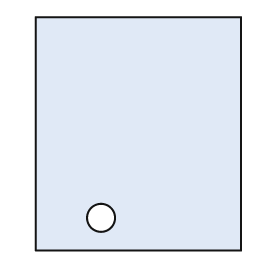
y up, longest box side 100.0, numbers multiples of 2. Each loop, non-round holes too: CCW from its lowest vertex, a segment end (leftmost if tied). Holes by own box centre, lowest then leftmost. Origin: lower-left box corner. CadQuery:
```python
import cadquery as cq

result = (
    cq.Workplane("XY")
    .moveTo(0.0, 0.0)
    .lineTo(88.0, 0.0)
    .lineTo(88.0, 100.0)
    .lineTo(0.0, 100.0)
    .close()
    .moveTo(28.0, 14.0)
    .circle(6.0)
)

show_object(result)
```